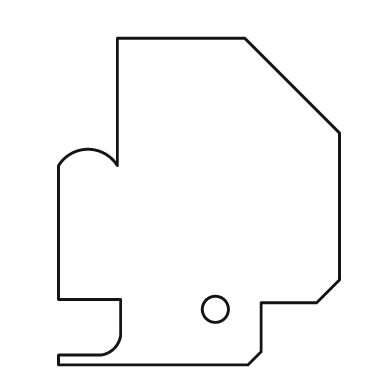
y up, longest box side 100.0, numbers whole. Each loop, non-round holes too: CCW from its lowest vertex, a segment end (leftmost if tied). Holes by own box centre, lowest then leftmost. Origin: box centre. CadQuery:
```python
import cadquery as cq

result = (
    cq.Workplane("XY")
    .moveTo(-43.0, -50.0)
    .lineTo(15.0, -50.0)
    .lineTo(19.0, -46.0)
    .lineTo(19.0, -31.0)
    .lineTo(36.0, -31.0)
    .lineTo(43.0, -24.0)
    .lineTo(43.0, 21.0)
    .lineTo(14.0, 50.0)
    .lineTo(-25.0, 50.0)
    .lineTo(-25.0, 11.0)
    .threePointArc((-34.0, 16.0), (-43.0, 11.0))
    .lineTo(-43.0, -30.0)
    .lineTo(-24.0, -30.0)
    .lineTo(-24.0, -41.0)
    .threePointArc((-26.0, -45.0), (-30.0, -47.0))
    .lineTo(-43.0, -47.0)
    .close()
    .moveTo(5.0, -33.0)
    .circle(4.0)
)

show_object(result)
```